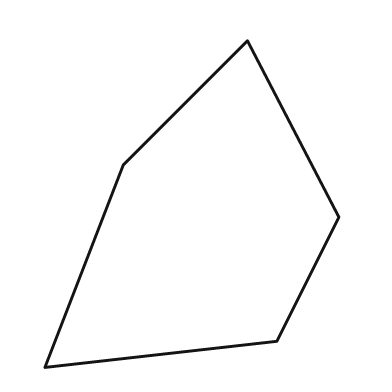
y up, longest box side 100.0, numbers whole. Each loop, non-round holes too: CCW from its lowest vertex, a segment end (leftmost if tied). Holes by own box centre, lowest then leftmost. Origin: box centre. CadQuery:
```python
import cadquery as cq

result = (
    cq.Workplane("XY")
    .moveTo(-45.0, -50.0)
    .lineTo(26.0, -42.0)
    .lineTo(45.0, -4.0)
    .lineTo(17.0, 50.0)
    .lineTo(-21.0, 12.0)
    .close()
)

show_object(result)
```